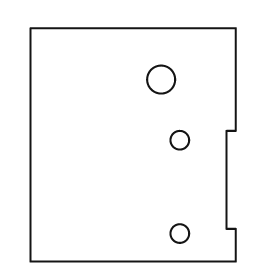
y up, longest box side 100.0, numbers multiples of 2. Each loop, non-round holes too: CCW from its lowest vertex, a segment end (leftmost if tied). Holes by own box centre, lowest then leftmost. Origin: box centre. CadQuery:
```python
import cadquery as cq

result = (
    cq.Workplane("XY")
    .moveTo(-44.0, -50.0)
    .lineTo(44.0, -50.0)
    .lineTo(44.0, -36.0)
    .lineTo(40.0, -36.0)
    .lineTo(40.0, 6.0)
    .lineTo(44.0, 6.0)
    .lineTo(44.0, 50.0)
    .lineTo(-44.0, 50.0)
    .close()
    .moveTo(20.0, -38.0)
    .circle(4.0)
    .moveTo(20.0, 2.0)
    .circle(4.0)
    .moveTo(12.0, 28.0)
    .circle(6.0)
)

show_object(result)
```